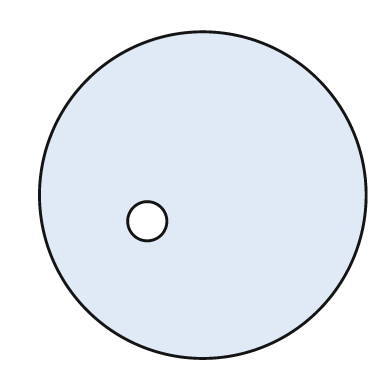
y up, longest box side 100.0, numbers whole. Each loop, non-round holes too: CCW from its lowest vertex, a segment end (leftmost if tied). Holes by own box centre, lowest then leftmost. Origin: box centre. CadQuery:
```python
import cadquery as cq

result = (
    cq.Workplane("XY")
    .moveTo(0.0, 0.0)
    .circle(50.0)
    .moveTo(-17.0, -8.0)
    .circle(6.0)
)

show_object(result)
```